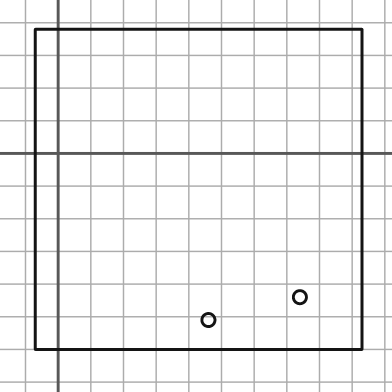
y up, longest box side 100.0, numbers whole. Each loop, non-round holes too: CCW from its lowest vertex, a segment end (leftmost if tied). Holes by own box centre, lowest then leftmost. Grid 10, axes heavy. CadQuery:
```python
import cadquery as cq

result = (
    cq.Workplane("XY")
    .moveTo(-7.0, -60.0)
    .lineTo(93.0, -60.0)
    .lineTo(93.0, 38.0)
    .lineTo(-7.0, 38.0)
    .close()
    .moveTo(46.0, -51.0)
    .circle(2.0)
    .moveTo(74.0, -44.0)
    .circle(2.0)
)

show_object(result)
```